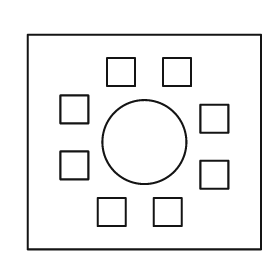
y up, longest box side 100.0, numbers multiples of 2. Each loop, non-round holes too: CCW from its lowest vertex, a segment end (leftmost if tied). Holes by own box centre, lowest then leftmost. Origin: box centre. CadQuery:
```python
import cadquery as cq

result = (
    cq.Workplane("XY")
    .moveTo(-50.0, -46.0)
    .lineTo(50.0, -46.0)
    .lineTo(50.0, 46.0)
    .lineTo(-50.0, 46.0)
    .close()
    .moveTo(-20.0, -36.0)
    .lineTo(-8.0, -36.0)
    .lineTo(-8.0, -24.0)
    .lineTo(-20.0, -24.0)
    .close()
    .moveTo(4.0, -36.0)
    .lineTo(16.0, -36.0)
    .lineTo(16.0, -24.0)
    .lineTo(4.0, -24.0)
    .close()
    .moveTo(24.0, -20.0)
    .lineTo(36.0, -20.0)
    .lineTo(36.0, -8.0)
    .lineTo(24.0, -8.0)
    .close()
    .moveTo(-36.0, -16.0)
    .lineTo(-24.0, -16.0)
    .lineTo(-24.0, -4.0)
    .lineTo(-36.0, -4.0)
    .close()
    .moveTo(0.0, 0.0)
    .circle(18.0)
    .moveTo(24.0, 4.0)
    .lineTo(36.0, 4.0)
    .lineTo(36.0, 16.0)
    .lineTo(24.0, 16.0)
    .close()
    .moveTo(-36.0, 8.0)
    .lineTo(-24.0, 8.0)
    .lineTo(-24.0, 20.0)
    .lineTo(-36.0, 20.0)
    .close()
    .moveTo(-16.0, 24.0)
    .lineTo(-4.0, 24.0)
    .lineTo(-4.0, 36.0)
    .lineTo(-16.0, 36.0)
    .close()
    .moveTo(8.0, 24.0)
    .lineTo(20.0, 24.0)
    .lineTo(20.0, 36.0)
    .lineTo(8.0, 36.0)
    .close()
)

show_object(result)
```